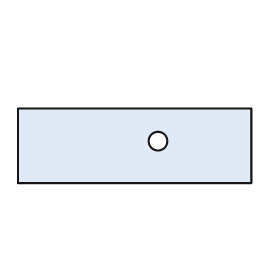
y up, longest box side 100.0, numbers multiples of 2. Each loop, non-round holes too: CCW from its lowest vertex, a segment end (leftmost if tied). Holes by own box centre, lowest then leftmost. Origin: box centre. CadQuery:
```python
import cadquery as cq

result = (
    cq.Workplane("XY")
    .moveTo(-50.0, -16.0)
    .lineTo(50.0, -16.0)
    .lineTo(50.0, 16.0)
    .lineTo(-50.0, 16.0)
    .close()
    .moveTo(10.0, 2.0)
    .circle(4.0)
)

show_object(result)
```